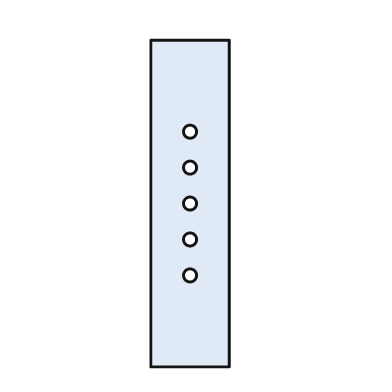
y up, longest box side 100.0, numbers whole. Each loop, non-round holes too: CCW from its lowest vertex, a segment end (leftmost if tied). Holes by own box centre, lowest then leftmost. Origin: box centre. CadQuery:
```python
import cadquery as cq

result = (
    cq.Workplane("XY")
    .moveTo(-12.0, -50.0)
    .lineTo(12.0, -50.0)
    .lineTo(12.0, 50.0)
    .lineTo(-12.0, 50.0)
    .close()
    .moveTo(0.0, -22.0)
    .circle(2.0)
    .moveTo(0.0, -11.0)
    .circle(2.0)
    .moveTo(0.0, 0.0)
    .circle(2.0)
    .moveTo(0.0, 11.0)
    .circle(2.0)
    .moveTo(0.0, 22.0)
    .circle(2.0)
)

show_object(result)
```